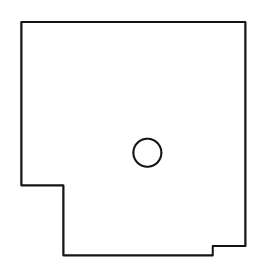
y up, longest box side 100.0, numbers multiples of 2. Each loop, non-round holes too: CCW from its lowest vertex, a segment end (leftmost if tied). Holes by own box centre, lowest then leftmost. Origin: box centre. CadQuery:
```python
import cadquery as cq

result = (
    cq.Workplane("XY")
    .moveTo(-30.0, -50.0)
    .lineTo(34.0, -50.0)
    .lineTo(34.0, -46.0)
    .lineTo(48.0, -46.0)
    .lineTo(48.0, 50.0)
    .lineTo(-48.0, 50.0)
    .lineTo(-48.0, -20.0)
    .lineTo(-30.0, -20.0)
    .close()
    .moveTo(6.0, -6.0)
    .circle(6.0)
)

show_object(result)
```